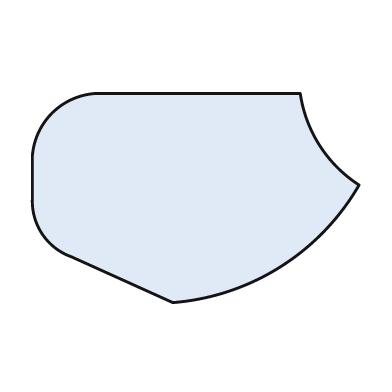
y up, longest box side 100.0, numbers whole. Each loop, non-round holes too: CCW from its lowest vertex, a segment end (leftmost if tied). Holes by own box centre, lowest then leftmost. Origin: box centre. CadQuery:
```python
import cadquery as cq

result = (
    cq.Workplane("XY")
    .moveTo(-7.0, -32.0)
    .threePointArc((26.0, -21.0), (50.0, 4.0))
    .threePointArc((38.0, 16.0), (32.0, 32.0))
    .lineTo(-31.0, 32.0)
    .threePointArc((-44.0, 26.0), (-50.0, 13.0))
    .lineTo(-50.0, 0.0)
    .threePointArc((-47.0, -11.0), (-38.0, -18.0))
    .close()
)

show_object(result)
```